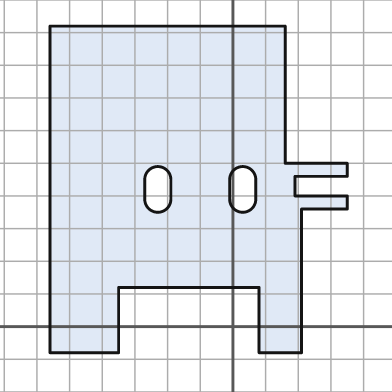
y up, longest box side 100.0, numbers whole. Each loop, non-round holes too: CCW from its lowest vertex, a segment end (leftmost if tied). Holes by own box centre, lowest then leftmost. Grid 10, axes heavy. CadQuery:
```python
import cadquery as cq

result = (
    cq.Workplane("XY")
    .moveTo(-56.0, -8.0)
    .lineTo(-35.0, -8.0)
    .lineTo(-35.0, 12.0)
    .lineTo(8.0, 12.0)
    .lineTo(8.0, -8.0)
    .lineTo(21.0, -8.0)
    .lineTo(21.0, 36.0)
    .lineTo(35.0, 36.0)
    .lineTo(35.0, 40.0)
    .lineTo(19.0, 40.0)
    .lineTo(19.0, 46.0)
    .lineTo(35.0, 46.0)
    .lineTo(35.0, 50.0)
    .lineTo(16.0, 50.0)
    .lineTo(16.0, 92.0)
    .lineTo(-56.0, 92.0)
    .close()
    .moveTo(-27.0, 39.0)
    .threePointArc((-23.0, 35.0), (-19.0, 39.0))
    .lineTo(-19.0, 45.0)
    .threePointArc((-23.0, 49.0), (-27.0, 45.0))
    .close()
    .moveTo(-1.0, 39.0)
    .threePointArc((3.0, 35.0), (7.0, 39.0))
    .lineTo(7.0, 45.0)
    .threePointArc((3.0, 49.0), (-1.0, 45.0))
    .close()
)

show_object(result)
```